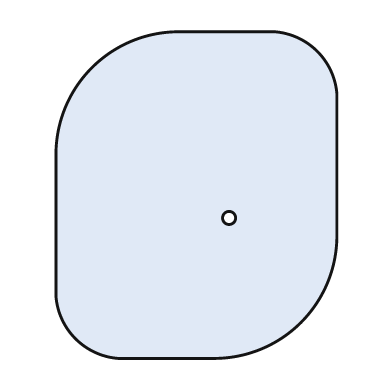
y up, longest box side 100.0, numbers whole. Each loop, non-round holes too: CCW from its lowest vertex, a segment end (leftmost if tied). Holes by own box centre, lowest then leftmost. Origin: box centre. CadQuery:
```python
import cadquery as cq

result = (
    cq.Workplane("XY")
    .moveTo(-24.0, -50.0)
    .lineTo(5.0, -50.0)
    .threePointArc((32.0, -39.0), (43.0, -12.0))
    .lineTo(43.0, 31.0)
    .threePointArc((37.0, 44.0), (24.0, 50.0))
    .lineTo(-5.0, 50.0)
    .threePointArc((-32.0, 39.0), (-43.0, 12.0))
    .lineTo(-43.0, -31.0)
    .threePointArc((-37.0, -44.0), (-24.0, -50.0))
    .close()
    .moveTo(10.0, -7.0)
    .circle(2.0)
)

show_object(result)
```